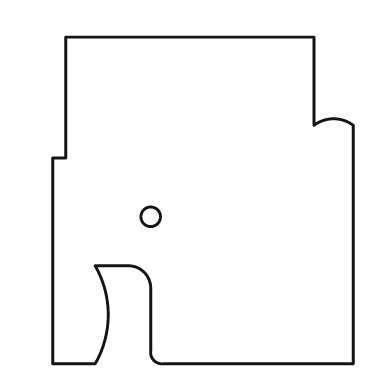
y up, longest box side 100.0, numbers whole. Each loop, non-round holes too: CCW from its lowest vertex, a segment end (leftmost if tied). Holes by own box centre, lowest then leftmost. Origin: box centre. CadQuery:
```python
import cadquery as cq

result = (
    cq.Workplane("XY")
    .moveTo(-46.0, -50.0)
    .lineTo(-33.0, -50.0)
    .threePointArc((-29.0, -35.0), (-33.0, -20.0))
    .lineTo(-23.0, -20.0)
    .threePointArc((-18.0, -22.0), (-16.0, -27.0))
    .lineTo(-16.0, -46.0)
    .threePointArc((-15.0, -49.0), (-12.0, -50.0))
    .lineTo(46.0, -50.0)
    .lineTo(46.0, 23.0)
    .threePointArc((40.0, 25.0), (34.0, 23.0))
    .lineTo(34.0, 50.0)
    .lineTo(-42.0, 50.0)
    .lineTo(-42.0, 13.0)
    .lineTo(-46.0, 13.0)
    .close()
    .moveTo(-16.0, -5.0)
    .circle(3.0)
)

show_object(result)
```